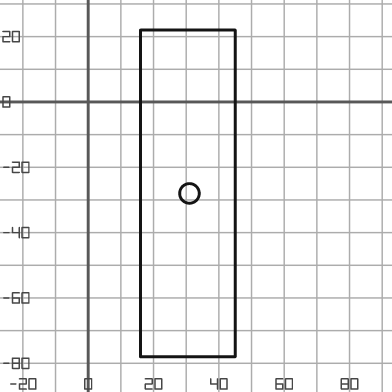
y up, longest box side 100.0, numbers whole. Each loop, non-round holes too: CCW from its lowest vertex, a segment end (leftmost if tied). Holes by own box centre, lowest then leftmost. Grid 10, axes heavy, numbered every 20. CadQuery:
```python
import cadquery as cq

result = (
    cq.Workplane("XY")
    .moveTo(16.0, -78.0)
    .lineTo(45.0, -78.0)
    .lineTo(45.0, 22.0)
    .lineTo(16.0, 22.0)
    .close()
    .moveTo(31.0, -28.0)
    .circle(3.0)
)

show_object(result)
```